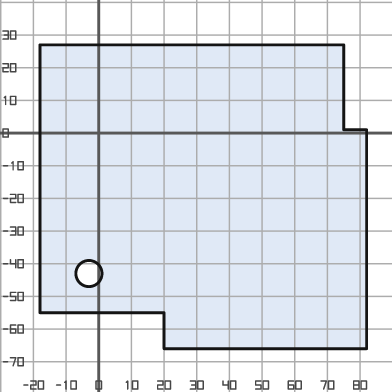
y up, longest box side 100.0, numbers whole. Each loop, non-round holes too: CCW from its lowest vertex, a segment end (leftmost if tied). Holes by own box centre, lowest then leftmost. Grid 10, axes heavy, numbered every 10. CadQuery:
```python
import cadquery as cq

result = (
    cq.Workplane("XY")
    .moveTo(20.0, -66.0)
    .lineTo(82.0, -66.0)
    .lineTo(82.0, 1.0)
    .lineTo(75.0, 1.0)
    .lineTo(75.0, 27.0)
    .lineTo(-18.0, 27.0)
    .lineTo(-18.0, -55.0)
    .lineTo(20.0, -55.0)
    .close()
    .moveTo(-3.0, -43.0)
    .circle(4.0)
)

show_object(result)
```